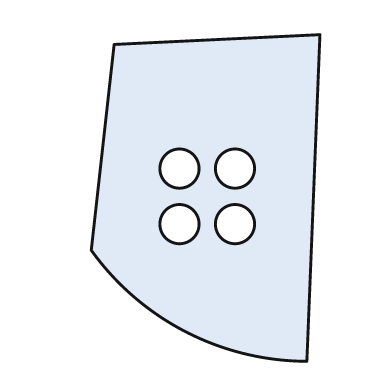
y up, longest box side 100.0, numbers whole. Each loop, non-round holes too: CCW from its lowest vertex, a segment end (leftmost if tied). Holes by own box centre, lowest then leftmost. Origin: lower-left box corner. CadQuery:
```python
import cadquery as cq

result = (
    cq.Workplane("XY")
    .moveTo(66.0, 0.0)
    .lineTo(70.0, 100.0)
    .lineTo(7.0, 97.0)
    .lineTo(0.0, 34.0)
    .threePointArc((29.0, 9.0), (66.0, 0.0))
    .close()
    .moveTo(27.0, 42.0)
    .circle(6.0)
    .moveTo(44.0, 42.0)
    .circle(6.0)
    .moveTo(27.0, 59.0)
    .circle(6.0)
    .moveTo(44.0, 59.0)
    .circle(6.0)
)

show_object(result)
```